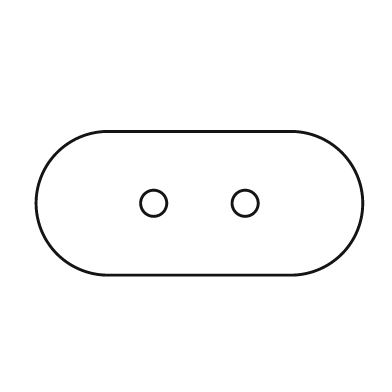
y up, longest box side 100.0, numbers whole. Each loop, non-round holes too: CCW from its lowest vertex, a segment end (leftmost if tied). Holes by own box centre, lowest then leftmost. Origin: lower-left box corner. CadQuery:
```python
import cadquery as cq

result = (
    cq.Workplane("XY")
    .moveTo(22.0, 0.0)
    .lineTo(78.0, 0.0)
    .threePointArc((100.0, 22.0), (78.0, 44.0))
    .lineTo(22.0, 44.0)
    .threePointArc((0.0, 22.0), (22.0, 0.0))
    .close()
    .moveTo(36.0, 22.0)
    .circle(4.0)
    .moveTo(64.0, 22.0)
    .circle(4.0)
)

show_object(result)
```